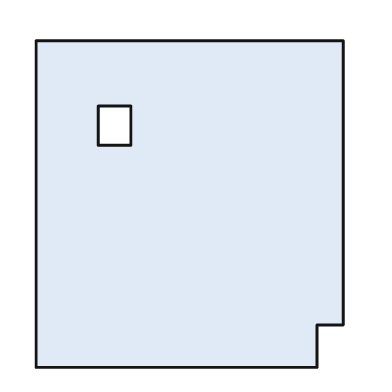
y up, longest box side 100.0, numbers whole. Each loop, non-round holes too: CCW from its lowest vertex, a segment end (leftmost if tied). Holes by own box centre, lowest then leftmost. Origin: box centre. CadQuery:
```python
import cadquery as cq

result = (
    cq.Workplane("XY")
    .moveTo(-47.0, -50.0)
    .lineTo(39.0, -50.0)
    .lineTo(39.0, -37.0)
    .lineTo(47.0, -37.0)
    .lineTo(47.0, 50.0)
    .lineTo(-47.0, 50.0)
    .close()
    .moveTo(-28.0, 18.0)
    .lineTo(-18.0, 18.0)
    .lineTo(-18.0, 30.0)
    .lineTo(-28.0, 30.0)
    .close()
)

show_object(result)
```